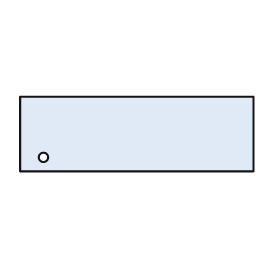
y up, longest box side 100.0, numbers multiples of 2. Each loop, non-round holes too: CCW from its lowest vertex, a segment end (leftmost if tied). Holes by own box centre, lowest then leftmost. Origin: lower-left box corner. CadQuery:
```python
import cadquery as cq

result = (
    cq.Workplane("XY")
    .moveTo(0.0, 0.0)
    .lineTo(100.0, 0.0)
    .lineTo(100.0, 32.0)
    .lineTo(0.0, 32.0)
    .close()
    .moveTo(10.0, 6.0)
    .circle(2.0)
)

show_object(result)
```